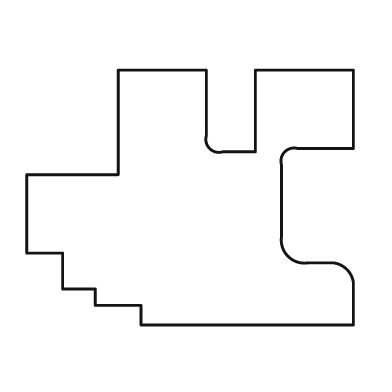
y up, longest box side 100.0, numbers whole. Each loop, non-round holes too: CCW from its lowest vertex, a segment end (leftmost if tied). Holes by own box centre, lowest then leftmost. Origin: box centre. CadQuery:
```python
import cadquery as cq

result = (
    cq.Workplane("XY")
    .moveTo(-15.0, -39.0)
    .lineTo(50.0, -39.0)
    .lineTo(50.0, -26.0)
    .threePointArc((48.0, -22.0), (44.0, -20.0))
    .lineTo(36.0, -20.0)
    .threePointArc((30.0, -18.0), (28.0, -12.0))
    .lineTo(28.0, 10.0)
    .threePointArc((29.0, 14.0), (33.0, 15.0))
    .lineTo(50.0, 15.0)
    .lineTo(50.0, 39.0)
    .lineTo(20.0, 39.0)
    .lineTo(20.0, 14.0)
    .lineTo(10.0, 14.0)
    .threePointArc((6.0, 15.0), (5.0, 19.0))
    .lineTo(5.0, 39.0)
    .lineTo(-22.0, 39.0)
    .lineTo(-22.0, 7.0)
    .lineTo(-50.0, 7.0)
    .lineTo(-50.0, -17.0)
    .lineTo(-39.0, -17.0)
    .lineTo(-39.0, -28.0)
    .lineTo(-29.0, -28.0)
    .lineTo(-29.0, -33.0)
    .lineTo(-15.0, -33.0)
    .close()
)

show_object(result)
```